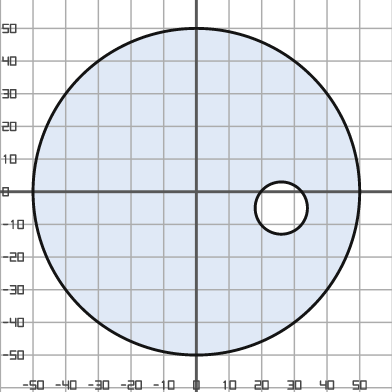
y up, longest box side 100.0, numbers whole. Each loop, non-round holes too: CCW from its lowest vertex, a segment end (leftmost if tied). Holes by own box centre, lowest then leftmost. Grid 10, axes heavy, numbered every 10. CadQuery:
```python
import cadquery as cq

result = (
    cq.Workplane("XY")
    .moveTo(0.0, 0.0)
    .circle(50.0)
    .moveTo(26.0, -5.0)
    .circle(8.0)
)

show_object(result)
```